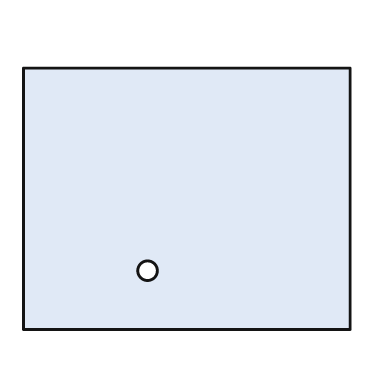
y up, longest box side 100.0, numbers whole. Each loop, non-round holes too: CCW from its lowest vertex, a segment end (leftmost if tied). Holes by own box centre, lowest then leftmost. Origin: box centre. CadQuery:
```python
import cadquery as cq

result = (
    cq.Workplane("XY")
    .moveTo(-50.0, -40.0)
    .lineTo(50.0, -40.0)
    .lineTo(50.0, 40.0)
    .lineTo(-50.0, 40.0)
    .close()
    .moveTo(-12.0, -22.0)
    .circle(3.0)
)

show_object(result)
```